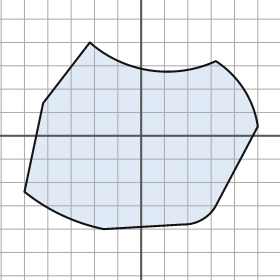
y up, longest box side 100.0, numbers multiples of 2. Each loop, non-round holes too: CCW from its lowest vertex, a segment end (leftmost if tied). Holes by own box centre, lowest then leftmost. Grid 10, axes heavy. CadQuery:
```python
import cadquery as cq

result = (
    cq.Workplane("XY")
    .moveTo(-16.0, -40.0)
    .lineTo(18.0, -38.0)
    .threePointArc((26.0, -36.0), (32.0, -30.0))
    .lineTo(50.0, 4.0)
    .threePointArc((44.0, 20.0), (32.0, 32.0))
    .threePointArc((4.0, 28.0), (-22.0, 40.0))
    .lineTo(-42.0, 14.0)
    .lineTo(-50.0, -24.0)
    .threePointArc((-34.0, -34.0), (-16.0, -40.0))
    .close()
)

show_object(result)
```